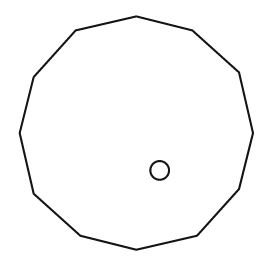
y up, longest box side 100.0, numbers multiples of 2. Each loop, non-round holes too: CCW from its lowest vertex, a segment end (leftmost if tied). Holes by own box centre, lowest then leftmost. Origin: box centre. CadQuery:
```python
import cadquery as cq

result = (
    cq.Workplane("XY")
    .moveTo(0.0, -50.0)
    .lineTo(26.0, -44.0)
    .lineTo(44.0, -24.0)
    .lineTo(50.0, 0.0)
    .lineTo(44.0, 26.0)
    .lineTo(24.0, 44.0)
    .lineTo(0.0, 50.0)
    .lineTo(-26.0, 44.0)
    .lineTo(-44.0, 24.0)
    .lineTo(-50.0, 0.0)
    .lineTo(-44.0, -26.0)
    .lineTo(-24.0, -44.0)
    .close()
    .moveTo(10.0, -16.0)
    .circle(4.0)
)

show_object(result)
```